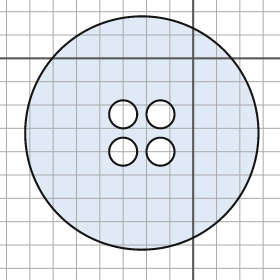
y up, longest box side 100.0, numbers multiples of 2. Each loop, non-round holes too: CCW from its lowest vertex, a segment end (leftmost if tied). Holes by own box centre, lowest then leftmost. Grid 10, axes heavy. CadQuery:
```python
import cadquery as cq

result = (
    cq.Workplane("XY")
    .moveTo(-22.0, -32.0)
    .circle(50.0)
    .moveTo(-30.0, -40.0)
    .circle(6.0)
    .moveTo(-14.0, -40.0)
    .circle(6.0)
    .moveTo(-30.0, -24.0)
    .circle(6.0)
    .moveTo(-14.0, -24.0)
    .circle(6.0)
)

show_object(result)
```